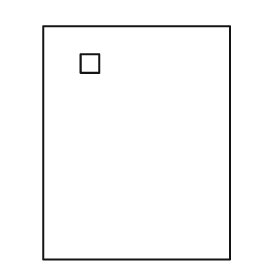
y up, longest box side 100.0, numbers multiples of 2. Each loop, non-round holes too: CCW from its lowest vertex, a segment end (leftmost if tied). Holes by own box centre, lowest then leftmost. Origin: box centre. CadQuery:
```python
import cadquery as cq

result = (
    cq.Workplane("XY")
    .moveTo(-40.0, -50.0)
    .lineTo(40.0, -50.0)
    .lineTo(40.0, 50.0)
    .lineTo(-40.0, 50.0)
    .close()
    .moveTo(-24.0, 30.0)
    .lineTo(-16.0, 30.0)
    .lineTo(-16.0, 38.0)
    .lineTo(-24.0, 38.0)
    .close()
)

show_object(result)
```